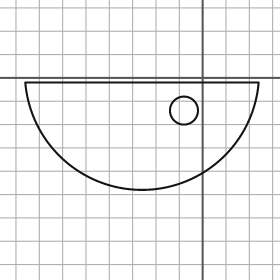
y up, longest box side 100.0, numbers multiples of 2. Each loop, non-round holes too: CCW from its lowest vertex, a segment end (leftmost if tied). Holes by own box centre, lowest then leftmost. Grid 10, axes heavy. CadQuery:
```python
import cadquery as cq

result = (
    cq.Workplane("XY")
    .moveTo(-76.0, -2.0)
    .threePointArc((-26.0, -48.0), (24.0, -2.0))
    .close()
    .moveTo(-8.0, -14.0)
    .circle(6.0)
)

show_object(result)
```